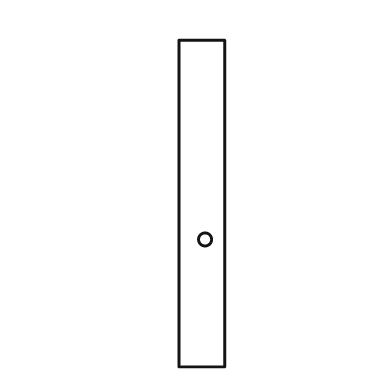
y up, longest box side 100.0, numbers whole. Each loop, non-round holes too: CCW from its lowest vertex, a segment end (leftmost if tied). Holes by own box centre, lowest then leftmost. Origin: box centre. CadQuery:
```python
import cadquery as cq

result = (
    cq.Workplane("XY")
    .moveTo(-7.0, -50.0)
    .lineTo(7.0, -50.0)
    .lineTo(7.0, 50.0)
    .lineTo(-7.0, 50.0)
    .close()
    .moveTo(1.0, -11.0)
    .circle(2.0)
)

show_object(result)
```